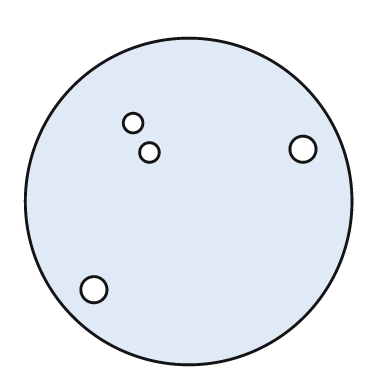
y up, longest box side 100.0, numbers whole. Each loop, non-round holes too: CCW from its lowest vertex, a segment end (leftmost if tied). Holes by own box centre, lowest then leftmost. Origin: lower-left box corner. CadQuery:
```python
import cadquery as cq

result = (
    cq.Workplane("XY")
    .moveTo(50.0, 50.0)
    .circle(50.0)
    .moveTo(21.0, 23.0)
    .circle(4.0)
    .moveTo(38.0, 65.0)
    .circle(3.0)
    .moveTo(85.0, 66.0)
    .circle(4.0)
    .moveTo(33.0, 74.0)
    .circle(3.0)
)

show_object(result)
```